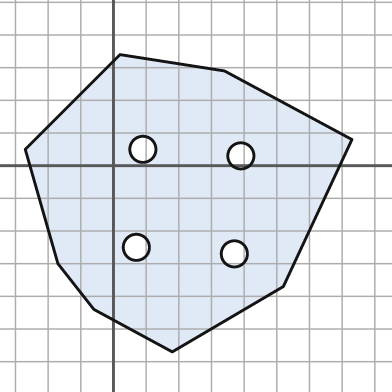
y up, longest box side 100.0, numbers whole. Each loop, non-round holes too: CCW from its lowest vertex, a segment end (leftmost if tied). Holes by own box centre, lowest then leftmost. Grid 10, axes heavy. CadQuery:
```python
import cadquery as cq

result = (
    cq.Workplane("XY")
    .moveTo(18.0, -57.0)
    .lineTo(52.0, -37.0)
    .lineTo(73.0, 8.0)
    .lineTo(34.0, 29.0)
    .lineTo(2.0, 34.0)
    .lineTo(-27.0, 5.0)
    .lineTo(-17.0, -30.0)
    .lineTo(-6.0, -44.0)
    .close()
    .moveTo(37.0, -27.0)
    .circle(4.0)
    .moveTo(7.0, -25.0)
    .circle(4.0)
    .moveTo(39.0, 3.0)
    .circle(4.0)
    .moveTo(9.0, 5.0)
    .circle(4.0)
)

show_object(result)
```